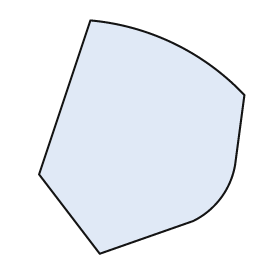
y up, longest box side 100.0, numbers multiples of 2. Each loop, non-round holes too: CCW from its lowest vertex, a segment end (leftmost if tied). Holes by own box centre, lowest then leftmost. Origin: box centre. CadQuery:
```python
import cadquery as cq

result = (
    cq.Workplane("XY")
    .moveTo(-18.0, -50.0)
    .lineTo(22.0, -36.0)
    .threePointArc((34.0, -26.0), (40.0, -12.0))
    .lineTo(44.0, 18.0)
    .threePointArc((14.0, 40.0), (-22.0, 50.0))
    .lineTo(-44.0, -16.0)
    .close()
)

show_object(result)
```